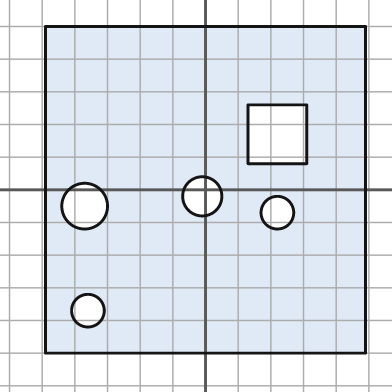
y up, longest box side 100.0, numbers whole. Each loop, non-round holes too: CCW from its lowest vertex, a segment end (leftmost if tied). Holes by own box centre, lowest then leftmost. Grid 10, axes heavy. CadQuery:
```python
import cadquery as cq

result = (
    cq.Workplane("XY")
    .moveTo(-49.0, -50.0)
    .lineTo(49.0, -50.0)
    .lineTo(49.0, 50.0)
    .lineTo(-49.0, 50.0)
    .close()
    .moveTo(-36.0, -37.0)
    .circle(5.0)
    .moveTo(22.0, -7.0)
    .circle(5.0)
    .moveTo(-37.0, -5.0)
    .circle(7.0)
    .moveTo(-1.0, -2.0)
    .circle(6.0)
    .moveTo(13.0, 8.0)
    .lineTo(31.0, 8.0)
    .lineTo(31.0, 26.0)
    .lineTo(13.0, 26.0)
    .close()
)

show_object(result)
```